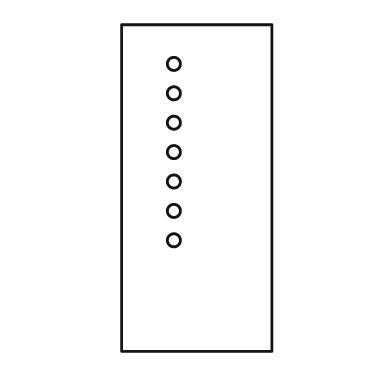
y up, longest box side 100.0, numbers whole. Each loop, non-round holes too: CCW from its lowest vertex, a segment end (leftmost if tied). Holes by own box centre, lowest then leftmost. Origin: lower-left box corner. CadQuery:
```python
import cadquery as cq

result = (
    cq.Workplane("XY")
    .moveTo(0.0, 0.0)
    .lineTo(46.0, 0.0)
    .lineTo(46.0, 100.0)
    .lineTo(0.0, 100.0)
    .close()
    .moveTo(16.0, 34.0)
    .circle(2.0)
    .moveTo(16.0, 43.0)
    .circle(2.0)
    .moveTo(16.0, 52.0)
    .circle(2.0)
    .moveTo(16.0, 61.0)
    .circle(2.0)
    .moveTo(16.0, 70.0)
    .circle(2.0)
    .moveTo(16.0, 79.0)
    .circle(2.0)
    .moveTo(16.0, 88.0)
    .circle(2.0)
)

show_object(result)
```